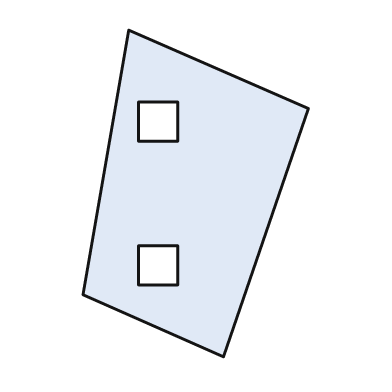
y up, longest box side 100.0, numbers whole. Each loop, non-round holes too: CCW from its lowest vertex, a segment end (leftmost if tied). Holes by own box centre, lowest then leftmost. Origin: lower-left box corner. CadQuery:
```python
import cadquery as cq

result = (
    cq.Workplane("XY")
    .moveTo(43.0, 0.0)
    .lineTo(69.0, 76.0)
    .lineTo(14.0, 100.0)
    .lineTo(0.0, 19.0)
    .close()
    .moveTo(17.0, 22.0)
    .lineTo(29.0, 22.0)
    .lineTo(29.0, 34.0)
    .lineTo(17.0, 34.0)
    .close()
    .moveTo(17.0, 66.0)
    .lineTo(29.0, 66.0)
    .lineTo(29.0, 78.0)
    .lineTo(17.0, 78.0)
    .close()
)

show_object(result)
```